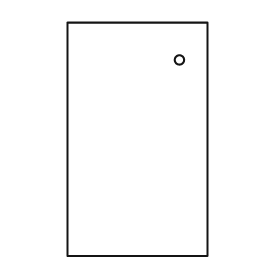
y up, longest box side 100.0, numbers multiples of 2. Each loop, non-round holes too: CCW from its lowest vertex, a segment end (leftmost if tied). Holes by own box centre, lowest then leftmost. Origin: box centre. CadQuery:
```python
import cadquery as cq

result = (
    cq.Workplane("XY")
    .moveTo(-30.0, -50.0)
    .lineTo(30.0, -50.0)
    .lineTo(30.0, 50.0)
    .lineTo(-30.0, 50.0)
    .close()
    .moveTo(18.0, 34.0)
    .circle(2.0)
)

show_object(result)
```